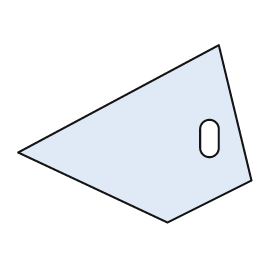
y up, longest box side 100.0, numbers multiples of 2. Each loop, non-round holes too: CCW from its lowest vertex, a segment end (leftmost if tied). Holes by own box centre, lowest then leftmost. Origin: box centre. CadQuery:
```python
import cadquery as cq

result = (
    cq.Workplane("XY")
    .moveTo(14.0, -38.0)
    .lineTo(50.0, -20.0)
    .lineTo(36.0, 38.0)
    .lineTo(-50.0, -8.0)
    .close()
    .moveTo(28.0, -6.0)
    .threePointArc((32.0, -10.0), (36.0, -6.0))
    .lineTo(36.0, 2.0)
    .threePointArc((32.0, 6.0), (28.0, 2.0))
    .close()
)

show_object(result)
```